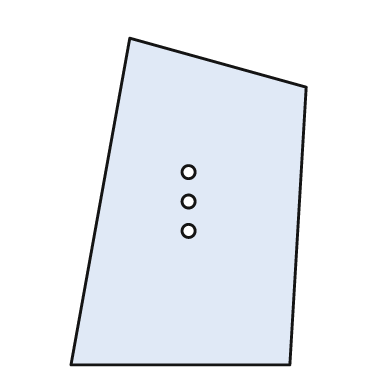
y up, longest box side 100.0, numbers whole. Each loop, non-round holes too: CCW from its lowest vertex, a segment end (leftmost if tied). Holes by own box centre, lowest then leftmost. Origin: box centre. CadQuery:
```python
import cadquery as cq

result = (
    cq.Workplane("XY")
    .moveTo(-36.0, -50.0)
    .lineTo(31.0, -50.0)
    .lineTo(36.0, 35.0)
    .lineTo(-18.0, 50.0)
    .close()
    .moveTo(0.0, -9.0)
    .circle(2.0)
    .moveTo(0.0, 0.0)
    .circle(2.0)
    .moveTo(0.0, 9.0)
    .circle(2.0)
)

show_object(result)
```